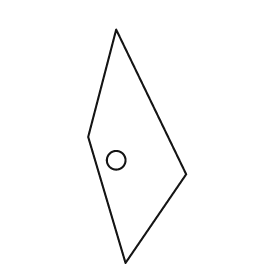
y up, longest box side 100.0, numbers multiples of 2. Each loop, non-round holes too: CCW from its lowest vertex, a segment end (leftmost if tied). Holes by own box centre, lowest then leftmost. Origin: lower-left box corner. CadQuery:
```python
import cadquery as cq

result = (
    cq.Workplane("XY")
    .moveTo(16.0, 0.0)
    .lineTo(42.0, 38.0)
    .lineTo(12.0, 100.0)
    .lineTo(0.0, 54.0)
    .close()
    .moveTo(12.0, 44.0)
    .circle(4.0)
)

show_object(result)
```